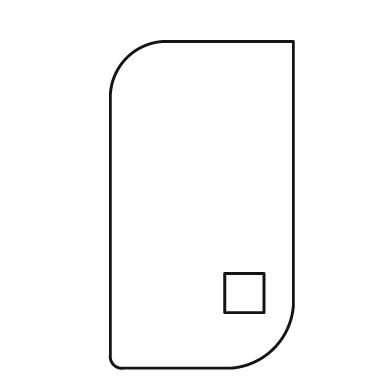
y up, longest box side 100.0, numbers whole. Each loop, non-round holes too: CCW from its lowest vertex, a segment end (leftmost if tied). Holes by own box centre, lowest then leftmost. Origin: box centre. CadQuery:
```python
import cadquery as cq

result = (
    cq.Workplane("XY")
    .moveTo(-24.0, -50.0)
    .lineTo(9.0, -50.0)
    .threePointArc((22.0, -44.0), (28.0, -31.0))
    .lineTo(28.0, 50.0)
    .lineTo(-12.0, 50.0)
    .threePointArc((-23.0, 45.0), (-28.0, 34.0))
    .lineTo(-28.0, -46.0)
    .threePointArc((-27.0, -49.0), (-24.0, -50.0))
    .close()
    .moveTo(7.0, -33.0)
    .lineTo(19.0, -33.0)
    .lineTo(19.0, -21.0)
    .lineTo(7.0, -21.0)
    .close()
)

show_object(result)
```